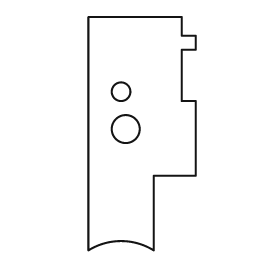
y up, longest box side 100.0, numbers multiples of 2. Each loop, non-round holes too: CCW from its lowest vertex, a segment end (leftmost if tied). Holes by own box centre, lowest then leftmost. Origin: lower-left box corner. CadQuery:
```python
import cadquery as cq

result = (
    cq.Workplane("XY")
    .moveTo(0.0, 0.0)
    .threePointArc((14.0, 4.0), (28.0, 0.0))
    .lineTo(28.0, 32.0)
    .lineTo(46.0, 32.0)
    .lineTo(46.0, 64.0)
    .lineTo(40.0, 64.0)
    .lineTo(40.0, 86.0)
    .lineTo(46.0, 86.0)
    .lineTo(46.0, 92.0)
    .lineTo(40.0, 92.0)
    .lineTo(40.0, 100.0)
    .lineTo(0.0, 100.0)
    .close()
    .moveTo(16.0, 52.0)
    .circle(6.0)
    .moveTo(14.0, 68.0)
    .circle(4.0)
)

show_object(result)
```